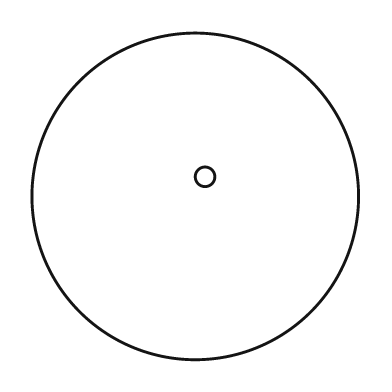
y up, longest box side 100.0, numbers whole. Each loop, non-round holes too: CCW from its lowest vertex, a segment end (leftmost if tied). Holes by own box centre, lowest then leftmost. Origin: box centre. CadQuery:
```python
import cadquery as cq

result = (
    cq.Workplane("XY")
    .moveTo(0.0, 0.0)
    .circle(50.0)
    .moveTo(3.0, 6.0)
    .circle(3.0)
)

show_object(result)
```